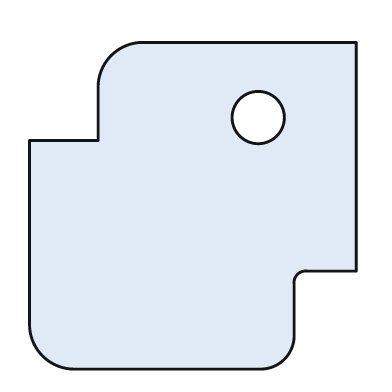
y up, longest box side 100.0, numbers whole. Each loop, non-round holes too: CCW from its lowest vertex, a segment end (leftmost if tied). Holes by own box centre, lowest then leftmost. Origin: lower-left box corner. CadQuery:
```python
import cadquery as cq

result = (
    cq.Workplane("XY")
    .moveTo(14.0, 0.0)
    .lineTo(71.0, 0.0)
    .threePointArc((78.0, 3.0), (81.0, 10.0))
    .lineTo(81.0, 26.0)
    .threePointArc((82.0, 29.0), (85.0, 30.0))
    .lineTo(100.0, 30.0)
    .lineTo(100.0, 100.0)
    .lineTo(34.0, 100.0)
    .threePointArc((25.0, 96.0), (21.0, 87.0))
    .lineTo(21.0, 70.0)
    .lineTo(0.0, 70.0)
    .lineTo(0.0, 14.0)
    .threePointArc((4.0, 4.0), (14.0, 0.0))
    .close()
    .moveTo(70.0, 77.0)
    .circle(8.0)
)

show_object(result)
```